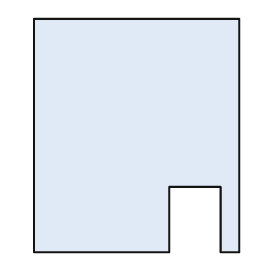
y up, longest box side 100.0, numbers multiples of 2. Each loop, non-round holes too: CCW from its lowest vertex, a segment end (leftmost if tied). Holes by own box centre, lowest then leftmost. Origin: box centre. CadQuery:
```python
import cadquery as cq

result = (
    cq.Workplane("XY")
    .moveTo(-44.0, -50.0)
    .lineTo(14.0, -50.0)
    .lineTo(14.0, -22.0)
    .lineTo(36.0, -22.0)
    .lineTo(36.0, -50.0)
    .lineTo(44.0, -50.0)
    .lineTo(44.0, 50.0)
    .lineTo(-44.0, 50.0)
    .close()
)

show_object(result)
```